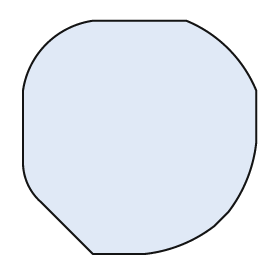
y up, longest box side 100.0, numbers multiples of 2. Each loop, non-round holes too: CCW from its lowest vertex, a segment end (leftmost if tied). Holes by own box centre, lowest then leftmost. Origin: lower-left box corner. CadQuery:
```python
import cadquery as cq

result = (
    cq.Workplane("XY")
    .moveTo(30.0, 0.0)
    .lineTo(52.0, 0.0)
    .threePointArc((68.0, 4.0), (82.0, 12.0))
    .lineTo(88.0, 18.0)
    .threePointArc((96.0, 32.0), (100.0, 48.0))
    .lineTo(100.0, 70.0)
    .threePointArc((88.0, 88.0), (70.0, 100.0))
    .lineTo(30.0, 100.0)
    .threePointArc((10.0, 90.0), (0.0, 70.0))
    .lineTo(0.0, 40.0)
    .threePointArc((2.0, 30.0), (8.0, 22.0))
    .close()
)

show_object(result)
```